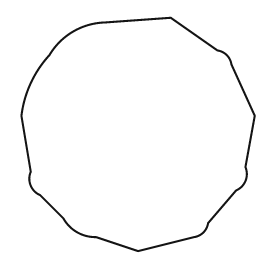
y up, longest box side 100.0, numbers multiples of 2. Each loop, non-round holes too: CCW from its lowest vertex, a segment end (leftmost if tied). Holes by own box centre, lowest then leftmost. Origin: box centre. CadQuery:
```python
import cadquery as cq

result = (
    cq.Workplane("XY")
    .moveTo(0.0, -50.0)
    .lineTo(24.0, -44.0)
    .threePointArc((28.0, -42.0), (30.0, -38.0))
    .lineTo(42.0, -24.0)
    .threePointArc((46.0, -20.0), (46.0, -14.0))
    .lineTo(50.0, 8.0)
    .lineTo(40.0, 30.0)
    .threePointArc((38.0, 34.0), (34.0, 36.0))
    .lineTo(14.0, 50.0)
    .lineTo(-14.0, 48.0)
    .threePointArc((-28.0, 44.0), (-38.0, 34.0))
    .threePointArc((-46.0, 22.0), (-50.0, 8.0))
    .lineTo(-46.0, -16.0)
    .threePointArc((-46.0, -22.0), (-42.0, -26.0))
    .lineTo(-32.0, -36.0)
    .threePointArc((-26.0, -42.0), (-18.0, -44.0))
    .close()
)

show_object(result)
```